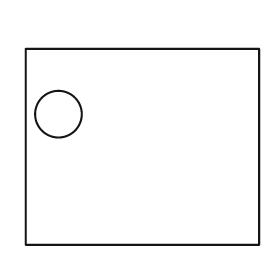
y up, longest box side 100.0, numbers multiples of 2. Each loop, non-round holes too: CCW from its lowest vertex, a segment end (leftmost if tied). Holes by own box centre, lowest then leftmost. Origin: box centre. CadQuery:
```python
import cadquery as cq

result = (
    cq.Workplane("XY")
    .moveTo(-50.0, -42.0)
    .lineTo(50.0, -42.0)
    .lineTo(50.0, 42.0)
    .lineTo(-50.0, 42.0)
    .close()
    .moveTo(-36.0, 14.0)
    .circle(10.0)
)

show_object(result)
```